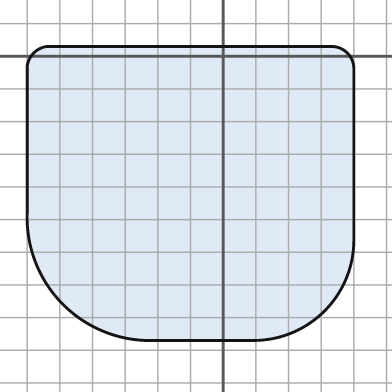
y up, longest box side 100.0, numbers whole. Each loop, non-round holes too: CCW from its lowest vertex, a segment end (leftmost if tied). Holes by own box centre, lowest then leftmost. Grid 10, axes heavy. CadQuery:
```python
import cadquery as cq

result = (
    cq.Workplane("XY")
    .moveTo(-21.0, -87.0)
    .lineTo(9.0, -87.0)
    .threePointArc((31.0, -78.0), (40.0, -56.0))
    .lineTo(40.0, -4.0)
    .threePointArc((38.0, 1.0), (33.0, 3.0))
    .lineTo(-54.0, 3.0)
    .threePointArc((-58.0, 1.0), (-60.0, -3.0))
    .lineTo(-60.0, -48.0)
    .threePointArc((-49.0, -76.0), (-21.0, -87.0))
    .close()
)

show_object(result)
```